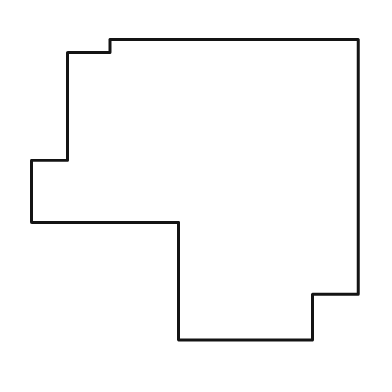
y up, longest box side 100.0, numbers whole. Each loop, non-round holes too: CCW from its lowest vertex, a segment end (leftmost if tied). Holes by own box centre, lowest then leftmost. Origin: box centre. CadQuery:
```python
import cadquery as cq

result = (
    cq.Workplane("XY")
    .moveTo(-5.0, -46.0)
    .lineTo(36.0, -46.0)
    .lineTo(36.0, -32.0)
    .lineTo(50.0, -32.0)
    .lineTo(50.0, 46.0)
    .lineTo(-26.0, 46.0)
    .lineTo(-26.0, 42.0)
    .lineTo(-39.0, 42.0)
    .lineTo(-39.0, 9.0)
    .lineTo(-50.0, 9.0)
    .lineTo(-50.0, -10.0)
    .lineTo(-5.0, -10.0)
    .close()
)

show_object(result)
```